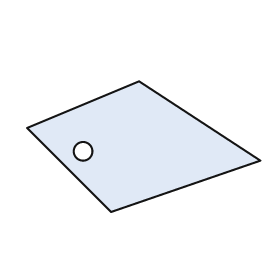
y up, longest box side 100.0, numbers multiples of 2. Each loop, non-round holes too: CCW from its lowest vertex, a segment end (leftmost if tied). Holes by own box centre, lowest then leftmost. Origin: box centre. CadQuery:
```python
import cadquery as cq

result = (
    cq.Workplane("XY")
    .moveTo(-14.0, -28.0)
    .lineTo(50.0, -6.0)
    .lineTo(-2.0, 28.0)
    .lineTo(-50.0, 8.0)
    .close()
    .moveTo(-26.0, -2.0)
    .circle(4.0)
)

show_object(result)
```